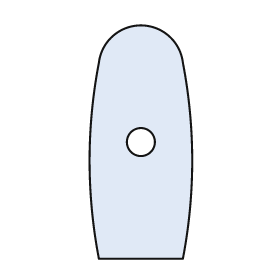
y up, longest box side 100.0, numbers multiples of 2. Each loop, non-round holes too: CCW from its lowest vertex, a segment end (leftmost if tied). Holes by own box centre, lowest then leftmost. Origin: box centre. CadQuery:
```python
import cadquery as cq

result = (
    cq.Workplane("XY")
    .moveTo(-18.0, -50.0)
    .lineTo(18.0, -50.0)
    .threePointArc((22.0, -8.0), (18.0, 34.0))
    .threePointArc((0.0, 50.0), (-18.0, 34.0))
    .threePointArc((-22.0, -8.0), (-18.0, -50.0))
    .close()
    .moveTo(0.0, 0.0)
    .circle(6.0)
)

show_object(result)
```